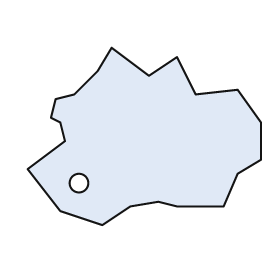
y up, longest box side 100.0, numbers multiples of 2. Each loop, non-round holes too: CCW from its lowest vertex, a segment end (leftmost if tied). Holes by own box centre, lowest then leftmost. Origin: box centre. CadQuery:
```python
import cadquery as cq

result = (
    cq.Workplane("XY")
    .moveTo(-18.0, -38.0)
    .lineTo(-6.0, -30.0)
    .lineTo(6.0, -28.0)
    .lineTo(14.0, -30.0)
    .lineTo(34.0, -30.0)
    .lineTo(40.0, -16.0)
    .lineTo(50.0, -10.0)
    .lineTo(50.0, 6.0)
    .lineTo(40.0, 20.0)
    .lineTo(22.0, 18.0)
    .lineTo(14.0, 34.0)
    .lineTo(2.0, 26.0)
    .lineTo(-14.0, 38.0)
    .lineTo(-20.0, 28.0)
    .lineTo(-30.0, 18.0)
    .lineTo(-38.0, 16.0)
    .lineTo(-40.0, 8.0)
    .lineTo(-36.0, 6.0)
    .lineTo(-34.0, -2.0)
    .lineTo(-50.0, -14.0)
    .lineTo(-36.0, -32.0)
    .close()
    .moveTo(-28.0, -20.0)
    .circle(4.0)
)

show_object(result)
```